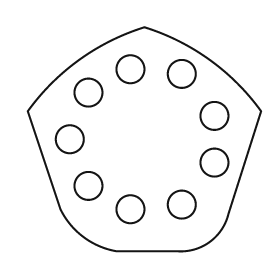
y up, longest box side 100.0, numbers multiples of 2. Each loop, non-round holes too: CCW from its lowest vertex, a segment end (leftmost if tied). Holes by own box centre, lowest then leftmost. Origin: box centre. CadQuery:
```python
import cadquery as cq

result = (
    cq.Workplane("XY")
    .moveTo(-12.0, -48.0)
    .lineTo(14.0, -48.0)
    .threePointArc((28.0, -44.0), (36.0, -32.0))
    .lineTo(50.0, 12.0)
    .threePointArc((28.0, 34.0), (0.0, 48.0))
    .threePointArc((-28.0, 34.0), (-50.0, 12.0))
    .lineTo(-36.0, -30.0)
    .threePointArc((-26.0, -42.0), (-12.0, -48.0))
    .close()
    .moveTo(-6.0, -30.0)
    .circle(6.0)
    .moveTo(16.0, -28.0)
    .circle(6.0)
    .moveTo(-24.0, -20.0)
    .circle(6.0)
    .moveTo(30.0, -10.0)
    .circle(6.0)
    .moveTo(-32.0, 0.0)
    .circle(6.0)
    .moveTo(30.0, 10.0)
    .circle(6.0)
    .moveTo(-24.0, 20.0)
    .circle(6.0)
    .moveTo(16.0, 28.0)
    .circle(6.0)
    .moveTo(-6.0, 30.0)
    .circle(6.0)
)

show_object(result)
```